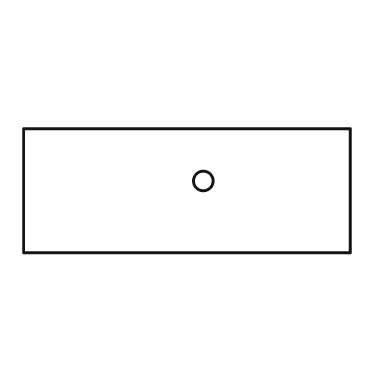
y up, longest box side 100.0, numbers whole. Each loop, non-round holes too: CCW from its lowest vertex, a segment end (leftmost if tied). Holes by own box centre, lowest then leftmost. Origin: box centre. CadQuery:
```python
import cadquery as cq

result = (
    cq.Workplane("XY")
    .moveTo(-50.0, -19.0)
    .lineTo(50.0, -19.0)
    .lineTo(50.0, 19.0)
    .lineTo(-50.0, 19.0)
    .close()
    .moveTo(5.0, 3.0)
    .circle(3.0)
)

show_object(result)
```